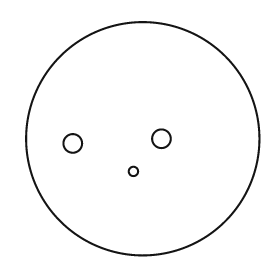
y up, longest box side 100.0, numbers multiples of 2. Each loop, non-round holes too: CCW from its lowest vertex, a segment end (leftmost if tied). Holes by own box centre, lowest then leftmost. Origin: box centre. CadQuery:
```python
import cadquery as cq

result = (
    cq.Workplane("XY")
    .moveTo(0.0, 0.0)
    .circle(50.0)
    .moveTo(-4.0, -14.0)
    .circle(2.0)
    .moveTo(-30.0, -2.0)
    .circle(4.0)
    .moveTo(8.0, 0.0)
    .circle(4.0)
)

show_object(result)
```